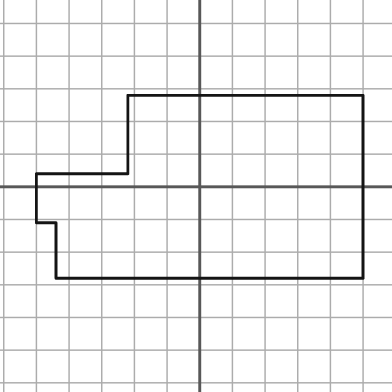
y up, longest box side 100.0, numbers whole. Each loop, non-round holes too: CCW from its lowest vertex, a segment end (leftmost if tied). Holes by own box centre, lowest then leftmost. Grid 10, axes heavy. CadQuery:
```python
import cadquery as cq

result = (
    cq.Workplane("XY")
    .moveTo(-44.0, -28.0)
    .lineTo(50.0, -28.0)
    .lineTo(50.0, 28.0)
    .lineTo(-22.0, 28.0)
    .lineTo(-22.0, 4.0)
    .lineTo(-50.0, 4.0)
    .lineTo(-50.0, -11.0)
    .lineTo(-44.0, -11.0)
    .close()
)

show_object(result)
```